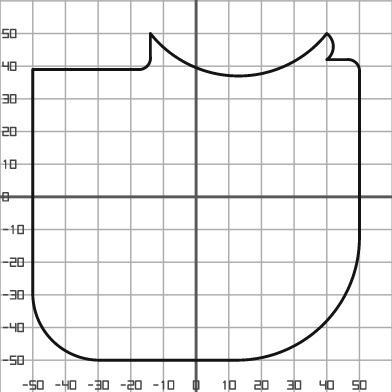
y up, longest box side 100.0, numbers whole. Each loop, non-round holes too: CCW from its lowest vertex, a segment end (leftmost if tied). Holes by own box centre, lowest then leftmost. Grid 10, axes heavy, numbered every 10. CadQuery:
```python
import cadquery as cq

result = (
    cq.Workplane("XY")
    .moveTo(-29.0, -50.0)
    .lineTo(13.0, -50.0)
    .threePointArc((39.0, -39.0), (50.0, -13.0))
    .lineTo(50.0, 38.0)
    .threePointArc((49.0, 41.0), (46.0, 42.0))
    .lineTo(40.0, 42.0)
    .threePointArc((42.0, 46.0), (40.0, 50.0))
    .threePointArc((13.0, 37.0), (-14.0, 50.0))
    .lineTo(-14.0, 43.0)
    .threePointArc((-15.0, 40.0), (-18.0, 39.0))
    .lineTo(-50.0, 39.0)
    .lineTo(-50.0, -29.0)
    .threePointArc((-44.0, -44.0), (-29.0, -50.0))
    .close()
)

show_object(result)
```